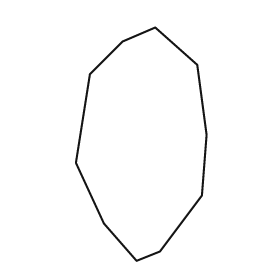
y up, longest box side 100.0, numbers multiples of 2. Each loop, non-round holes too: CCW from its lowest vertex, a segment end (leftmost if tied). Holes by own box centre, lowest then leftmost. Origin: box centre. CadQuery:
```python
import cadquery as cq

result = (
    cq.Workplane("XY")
    .moveTo(-2.0, -50.0)
    .lineTo(8.0, -46.0)
    .lineTo(26.0, -22.0)
    .lineTo(28.0, 4.0)
    .lineTo(24.0, 34.0)
    .lineTo(6.0, 50.0)
    .lineTo(-8.0, 44.0)
    .lineTo(-22.0, 30.0)
    .lineTo(-28.0, -8.0)
    .lineTo(-16.0, -34.0)
    .close()
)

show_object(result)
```